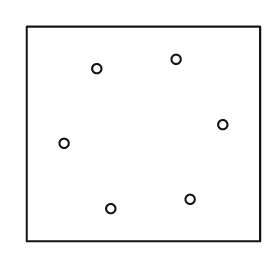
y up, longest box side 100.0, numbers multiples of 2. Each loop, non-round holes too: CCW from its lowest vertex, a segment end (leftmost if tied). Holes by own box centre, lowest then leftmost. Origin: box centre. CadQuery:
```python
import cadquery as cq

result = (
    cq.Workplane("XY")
    .moveTo(-50.0, -46.0)
    .lineTo(50.0, -46.0)
    .lineTo(50.0, 46.0)
    .lineTo(-50.0, 46.0)
    .close()
    .moveTo(-14.0, -32.0)
    .circle(2.0)
    .moveTo(20.0, -28.0)
    .circle(2.0)
    .moveTo(-34.0, -4.0)
    .circle(2.0)
    .moveTo(34.0, 4.0)
    .circle(2.0)
    .moveTo(-20.0, 28.0)
    .circle(2.0)
    .moveTo(14.0, 32.0)
    .circle(2.0)
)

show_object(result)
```